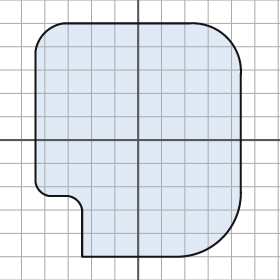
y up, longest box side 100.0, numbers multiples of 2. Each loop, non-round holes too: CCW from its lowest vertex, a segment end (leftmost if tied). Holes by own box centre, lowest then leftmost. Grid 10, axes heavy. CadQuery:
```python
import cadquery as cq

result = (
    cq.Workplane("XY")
    .moveTo(-24.0, -50.0)
    .lineTo(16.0, -50.0)
    .threePointArc((36.0, -42.0), (44.0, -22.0))
    .lineTo(44.0, 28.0)
    .threePointArc((38.0, 44.0), (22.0, 50.0))
    .lineTo(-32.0, 50.0)
    .threePointArc((-40.0, 46.0), (-44.0, 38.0))
    .lineTo(-44.0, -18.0)
    .threePointArc((-42.0, -22.0), (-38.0, -24.0))
    .lineTo(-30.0, -24.0)
    .threePointArc((-26.0, -26.0), (-24.0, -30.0))
    .close()
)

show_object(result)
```